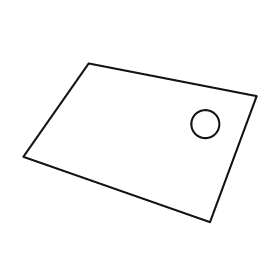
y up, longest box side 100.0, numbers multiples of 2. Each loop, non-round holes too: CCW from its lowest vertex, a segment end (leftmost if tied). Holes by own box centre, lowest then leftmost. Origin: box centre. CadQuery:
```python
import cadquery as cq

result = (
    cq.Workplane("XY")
    .moveTo(30.0, -34.0)
    .lineTo(50.0, 20.0)
    .lineTo(-22.0, 34.0)
    .lineTo(-50.0, -6.0)
    .close()
    .moveTo(28.0, 8.0)
    .circle(6.0)
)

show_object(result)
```